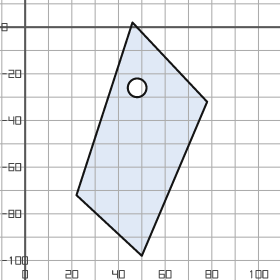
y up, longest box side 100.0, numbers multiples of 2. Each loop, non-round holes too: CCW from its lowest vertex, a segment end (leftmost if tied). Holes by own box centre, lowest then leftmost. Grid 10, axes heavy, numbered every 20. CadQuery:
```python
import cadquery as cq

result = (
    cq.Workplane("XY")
    .moveTo(50.0, -98.0)
    .lineTo(78.0, -32.0)
    .lineTo(46.0, 2.0)
    .lineTo(22.0, -72.0)
    .close()
    .moveTo(48.0, -26.0)
    .circle(4.0)
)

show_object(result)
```